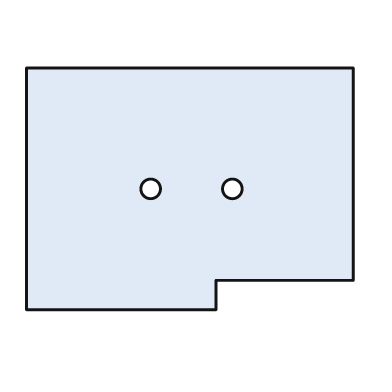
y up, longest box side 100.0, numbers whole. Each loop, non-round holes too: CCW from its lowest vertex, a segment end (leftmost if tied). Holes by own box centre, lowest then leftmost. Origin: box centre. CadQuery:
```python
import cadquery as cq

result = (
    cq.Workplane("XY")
    .moveTo(-50.0, -37.0)
    .lineTo(8.0, -37.0)
    .lineTo(8.0, -28.0)
    .lineTo(50.0, -28.0)
    .lineTo(50.0, 37.0)
    .lineTo(-50.0, 37.0)
    .close()
    .moveTo(-12.0, 0.0)
    .circle(3.0)
    .moveTo(13.0, 0.0)
    .circle(3.0)
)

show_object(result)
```